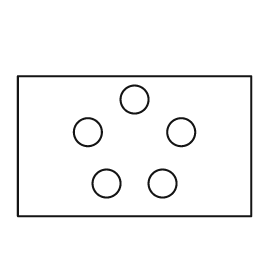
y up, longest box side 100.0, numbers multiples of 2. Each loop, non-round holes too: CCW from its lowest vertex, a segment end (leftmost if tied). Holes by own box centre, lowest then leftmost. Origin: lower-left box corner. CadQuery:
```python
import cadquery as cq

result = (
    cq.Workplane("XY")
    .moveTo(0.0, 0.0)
    .lineTo(100.0, 0.0)
    .lineTo(100.0, 60.0)
    .lineTo(0.0, 60.0)
    .close()
    .moveTo(38.0, 14.0)
    .circle(6.0)
    .moveTo(62.0, 14.0)
    .circle(6.0)
    .moveTo(30.0, 36.0)
    .circle(6.0)
    .moveTo(70.0, 36.0)
    .circle(6.0)
    .moveTo(50.0, 50.0)
    .circle(6.0)
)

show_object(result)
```